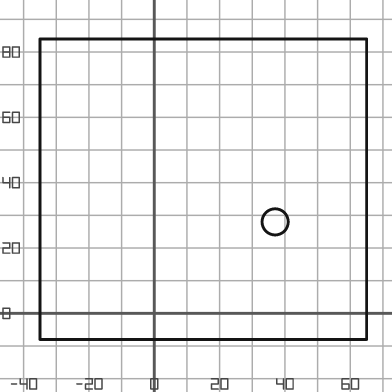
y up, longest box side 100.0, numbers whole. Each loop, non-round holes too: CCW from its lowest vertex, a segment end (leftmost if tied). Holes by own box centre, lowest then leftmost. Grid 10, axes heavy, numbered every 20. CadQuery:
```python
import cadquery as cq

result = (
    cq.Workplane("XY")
    .moveTo(-35.0, -8.0)
    .lineTo(65.0, -8.0)
    .lineTo(65.0, 84.0)
    .lineTo(-35.0, 84.0)
    .close()
    .moveTo(37.0, 28.0)
    .circle(4.0)
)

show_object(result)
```